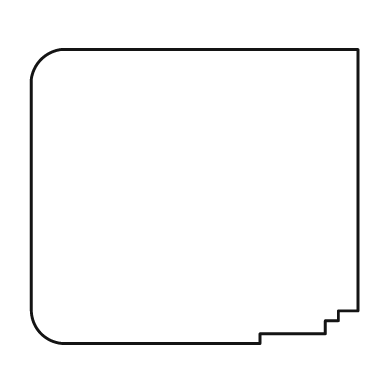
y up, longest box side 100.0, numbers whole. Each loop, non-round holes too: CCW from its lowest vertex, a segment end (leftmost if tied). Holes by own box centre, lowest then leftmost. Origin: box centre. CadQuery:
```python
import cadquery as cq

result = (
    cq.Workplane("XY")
    .moveTo(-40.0, -45.0)
    .lineTo(20.0, -45.0)
    .lineTo(20.0, -42.0)
    .lineTo(40.0, -42.0)
    .lineTo(40.0, -38.0)
    .lineTo(44.0, -38.0)
    .lineTo(44.0, -35.0)
    .lineTo(50.0, -35.0)
    .lineTo(50.0, 45.0)
    .lineTo(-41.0, 45.0)
    .threePointArc((-47.0, 42.0), (-50.0, 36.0))
    .lineTo(-50.0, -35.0)
    .threePointArc((-47.0, -42.0), (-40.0, -45.0))
    .close()
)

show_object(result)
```